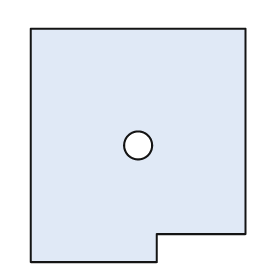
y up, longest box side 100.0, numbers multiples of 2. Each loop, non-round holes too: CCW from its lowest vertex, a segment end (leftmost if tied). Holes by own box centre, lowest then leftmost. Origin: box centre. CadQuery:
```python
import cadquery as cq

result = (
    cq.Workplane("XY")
    .moveTo(-46.0, -50.0)
    .lineTo(8.0, -50.0)
    .lineTo(8.0, -38.0)
    .lineTo(46.0, -38.0)
    .lineTo(46.0, 50.0)
    .lineTo(-46.0, 50.0)
    .close()
    .moveTo(0.0, 0.0)
    .circle(6.0)
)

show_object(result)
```